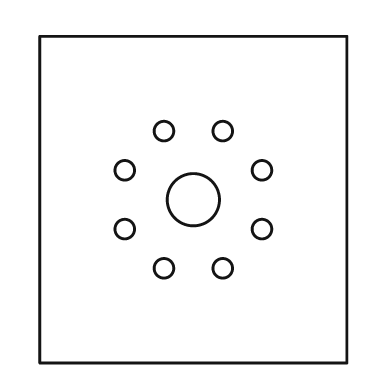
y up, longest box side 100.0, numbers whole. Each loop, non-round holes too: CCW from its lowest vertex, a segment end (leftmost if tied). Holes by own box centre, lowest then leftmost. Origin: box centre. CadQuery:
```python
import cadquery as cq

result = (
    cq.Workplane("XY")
    .moveTo(-47.0, -50.0)
    .lineTo(47.0, -50.0)
    .lineTo(47.0, 50.0)
    .lineTo(-47.0, 50.0)
    .close()
    .moveTo(-9.0, -21.0)
    .circle(3.0)
    .moveTo(9.0, -21.0)
    .circle(3.0)
    .moveTo(-21.0, -9.0)
    .circle(3.0)
    .moveTo(21.0, -9.0)
    .circle(3.0)
    .moveTo(0.0, 0.0)
    .circle(8.0)
    .moveTo(-21.0, 9.0)
    .circle(3.0)
    .moveTo(21.0, 9.0)
    .circle(3.0)
    .moveTo(-9.0, 21.0)
    .circle(3.0)
    .moveTo(9.0, 21.0)
    .circle(3.0)
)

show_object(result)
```